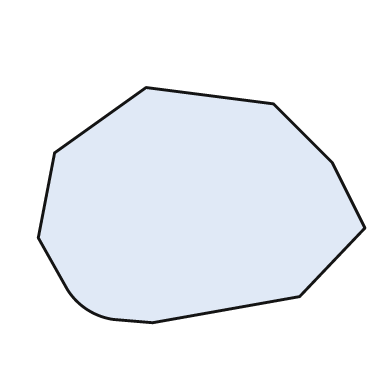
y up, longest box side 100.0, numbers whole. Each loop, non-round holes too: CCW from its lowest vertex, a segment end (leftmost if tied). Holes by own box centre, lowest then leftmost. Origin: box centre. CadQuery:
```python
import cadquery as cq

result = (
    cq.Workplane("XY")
    .moveTo(-15.0, -36.0)
    .lineTo(30.0, -28.0)
    .lineTo(50.0, -7.0)
    .lineTo(40.0, 13.0)
    .lineTo(22.0, 31.0)
    .lineTo(-17.0, 36.0)
    .lineTo(-45.0, 16.0)
    .lineTo(-50.0, -10.0)
    .lineTo(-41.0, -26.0)
    .threePointArc((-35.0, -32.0), (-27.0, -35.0))
    .close()
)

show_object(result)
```